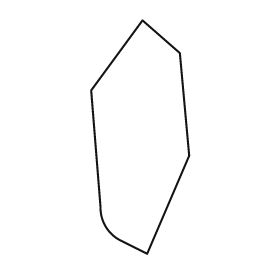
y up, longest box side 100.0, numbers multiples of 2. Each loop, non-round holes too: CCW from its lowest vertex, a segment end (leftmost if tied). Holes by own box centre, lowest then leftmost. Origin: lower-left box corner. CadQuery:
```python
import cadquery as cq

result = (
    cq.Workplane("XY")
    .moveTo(24.0, 0.0)
    .lineTo(42.0, 42.0)
    .lineTo(38.0, 86.0)
    .lineTo(22.0, 100.0)
    .lineTo(0.0, 70.0)
    .lineTo(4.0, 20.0)
    .threePointArc((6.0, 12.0), (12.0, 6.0))
    .close()
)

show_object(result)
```